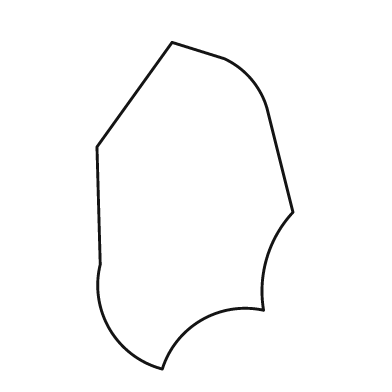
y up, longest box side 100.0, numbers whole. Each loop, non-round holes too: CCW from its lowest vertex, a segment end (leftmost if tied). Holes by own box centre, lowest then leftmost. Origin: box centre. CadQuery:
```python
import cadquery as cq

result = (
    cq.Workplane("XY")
    .moveTo(-10.0, -50.0)
    .threePointArc((2.0, -35.0), (21.0, -32.0))
    .threePointArc((22.0, -16.0), (30.0, -2.0))
    .lineTo(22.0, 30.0)
    .threePointArc((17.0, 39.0), (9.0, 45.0))
    .lineTo(-7.0, 50.0)
    .lineTo(-30.0, 18.0)
    .lineTo(-29.0, -18.0)
    .threePointArc((-26.0, -38.0), (-10.0, -50.0))
    .close()
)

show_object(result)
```